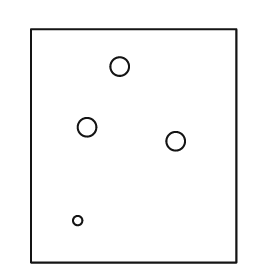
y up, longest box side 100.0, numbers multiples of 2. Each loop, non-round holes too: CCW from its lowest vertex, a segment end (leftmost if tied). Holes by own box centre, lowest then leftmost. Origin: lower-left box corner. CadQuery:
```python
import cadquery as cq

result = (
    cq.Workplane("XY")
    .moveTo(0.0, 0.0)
    .lineTo(88.0, 0.0)
    .lineTo(88.0, 100.0)
    .lineTo(0.0, 100.0)
    .close()
    .moveTo(20.0, 18.0)
    .circle(2.0)
    .moveTo(62.0, 52.0)
    .circle(4.0)
    .moveTo(24.0, 58.0)
    .circle(4.0)
    .moveTo(38.0, 84.0)
    .circle(4.0)
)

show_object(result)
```